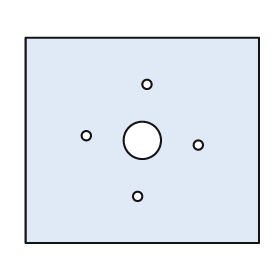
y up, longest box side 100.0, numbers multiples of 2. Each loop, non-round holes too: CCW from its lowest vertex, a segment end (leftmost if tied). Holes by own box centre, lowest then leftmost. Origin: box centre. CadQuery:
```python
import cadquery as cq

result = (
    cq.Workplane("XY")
    .moveTo(-50.0, -44.0)
    .lineTo(50.0, -44.0)
    .lineTo(50.0, 44.0)
    .lineTo(-50.0, 44.0)
    .close()
    .moveTo(-2.0, -24.0)
    .circle(2.0)
    .moveTo(24.0, -2.0)
    .circle(2.0)
    .moveTo(0.0, 0.0)
    .circle(8.0)
    .moveTo(-24.0, 2.0)
    .circle(2.0)
    .moveTo(2.0, 24.0)
    .circle(2.0)
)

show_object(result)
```